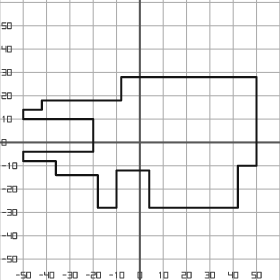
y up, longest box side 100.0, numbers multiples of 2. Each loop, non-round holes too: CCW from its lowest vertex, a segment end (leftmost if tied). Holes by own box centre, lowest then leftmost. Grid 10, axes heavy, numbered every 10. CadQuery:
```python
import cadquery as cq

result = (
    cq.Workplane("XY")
    .moveTo(-18.0, -28.0)
    .lineTo(-10.0, -28.0)
    .lineTo(-10.0, -12.0)
    .lineTo(4.0, -12.0)
    .lineTo(4.0, -28.0)
    .lineTo(42.0, -28.0)
    .lineTo(42.0, -10.0)
    .lineTo(50.0, -10.0)
    .lineTo(50.0, 28.0)
    .lineTo(-8.0, 28.0)
    .lineTo(-8.0, 18.0)
    .lineTo(-42.0, 18.0)
    .lineTo(-42.0, 14.0)
    .lineTo(-50.0, 14.0)
    .lineTo(-50.0, 10.0)
    .lineTo(-20.0, 10.0)
    .lineTo(-20.0, -4.0)
    .lineTo(-50.0, -4.0)
    .lineTo(-50.0, -8.0)
    .lineTo(-36.0, -8.0)
    .lineTo(-36.0, -14.0)
    .lineTo(-18.0, -14.0)
    .close()
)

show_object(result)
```